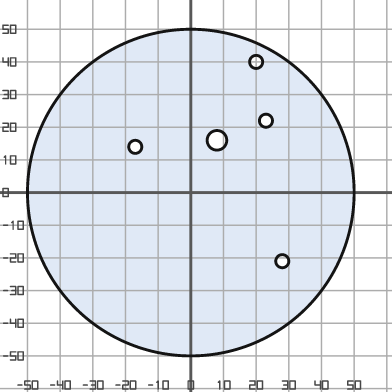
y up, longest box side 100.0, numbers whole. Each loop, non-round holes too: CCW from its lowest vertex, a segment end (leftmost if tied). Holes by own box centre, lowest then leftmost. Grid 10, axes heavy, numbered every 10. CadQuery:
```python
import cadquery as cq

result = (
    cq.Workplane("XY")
    .moveTo(0.0, 0.0)
    .circle(50.0)
    .moveTo(28.0, -21.0)
    .circle(2.0)
    .moveTo(-17.0, 14.0)
    .circle(2.0)
    .moveTo(8.0, 16.0)
    .circle(3.0)
    .moveTo(23.0, 22.0)
    .circle(2.0)
    .moveTo(20.0, 40.0)
    .circle(2.0)
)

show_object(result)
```